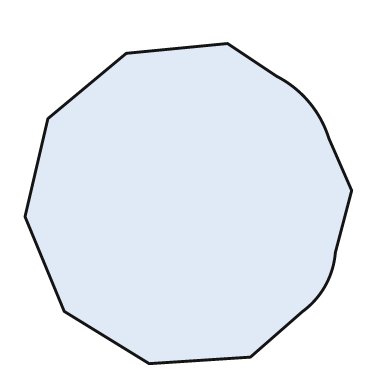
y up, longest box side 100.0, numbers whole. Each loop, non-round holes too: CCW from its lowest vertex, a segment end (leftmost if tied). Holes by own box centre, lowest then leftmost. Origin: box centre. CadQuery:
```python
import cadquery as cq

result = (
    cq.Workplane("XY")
    .moveTo(-12.0, -49.0)
    .lineTo(19.0, -47.0)
    .lineTo(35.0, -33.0)
    .threePointArc((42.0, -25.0), (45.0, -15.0))
    .lineTo(50.0, 4.0)
    .lineTo(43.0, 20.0)
    .threePointArc((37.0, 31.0), (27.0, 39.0))
    .lineTo(12.0, 49.0)
    .lineTo(-19.0, 46.0)
    .lineTo(-43.0, 26.0)
    .lineTo(-50.0, -4.0)
    .lineTo(-38.0, -33.0)
    .close()
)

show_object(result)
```